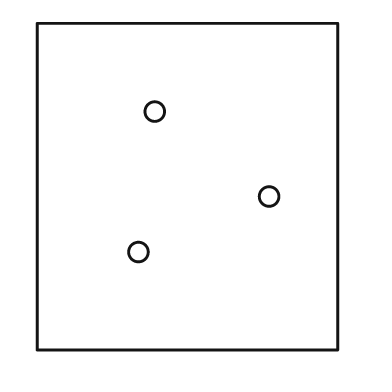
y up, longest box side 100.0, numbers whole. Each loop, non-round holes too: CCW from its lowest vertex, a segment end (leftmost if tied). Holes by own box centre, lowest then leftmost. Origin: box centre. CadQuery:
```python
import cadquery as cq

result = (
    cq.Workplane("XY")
    .moveTo(-46.0, -50.0)
    .lineTo(46.0, -50.0)
    .lineTo(46.0, 50.0)
    .lineTo(-46.0, 50.0)
    .close()
    .moveTo(-15.0, -20.0)
    .circle(3.0)
    .moveTo(25.0, -3.0)
    .circle(3.0)
    .moveTo(-10.0, 23.0)
    .circle(3.0)
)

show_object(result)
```